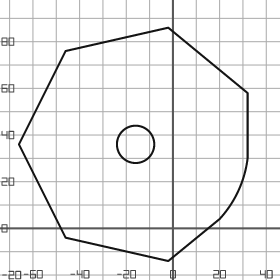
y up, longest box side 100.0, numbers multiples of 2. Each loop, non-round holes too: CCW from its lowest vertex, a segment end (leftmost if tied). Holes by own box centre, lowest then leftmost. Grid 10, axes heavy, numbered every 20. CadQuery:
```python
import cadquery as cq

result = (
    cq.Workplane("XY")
    .moveTo(-2.0, -14.0)
    .lineTo(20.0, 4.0)
    .threePointArc((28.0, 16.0), (32.0, 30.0))
    .lineTo(32.0, 58.0)
    .lineTo(-2.0, 86.0)
    .lineTo(-46.0, 76.0)
    .lineTo(-66.0, 36.0)
    .lineTo(-46.0, -4.0)
    .close()
    .moveTo(-16.0, 36.0)
    .circle(8.0)
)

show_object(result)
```